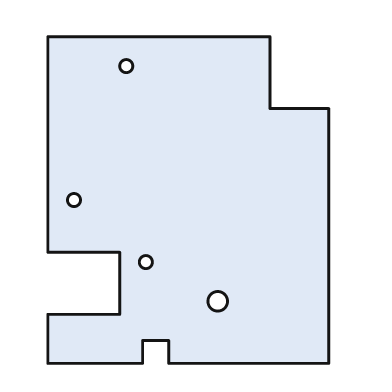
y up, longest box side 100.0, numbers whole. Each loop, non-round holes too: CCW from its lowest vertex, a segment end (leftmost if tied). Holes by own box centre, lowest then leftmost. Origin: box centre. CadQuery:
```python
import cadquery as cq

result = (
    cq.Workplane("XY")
    .moveTo(-43.0, -50.0)
    .lineTo(-14.0, -50.0)
    .lineTo(-14.0, -43.0)
    .lineTo(-6.0, -43.0)
    .lineTo(-6.0, -50.0)
    .lineTo(43.0, -50.0)
    .lineTo(43.0, 28.0)
    .lineTo(25.0, 28.0)
    .lineTo(25.0, 50.0)
    .lineTo(-43.0, 50.0)
    .lineTo(-43.0, -16.0)
    .lineTo(-21.0, -16.0)
    .lineTo(-21.0, -35.0)
    .lineTo(-43.0, -35.0)
    .close()
    .moveTo(9.0, -31.0)
    .circle(3.0)
    .moveTo(-13.0, -19.0)
    .circle(2.0)
    .moveTo(-35.0, 0.0)
    .circle(2.0)
    .moveTo(-19.0, 41.0)
    .circle(2.0)
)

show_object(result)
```